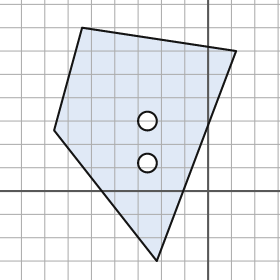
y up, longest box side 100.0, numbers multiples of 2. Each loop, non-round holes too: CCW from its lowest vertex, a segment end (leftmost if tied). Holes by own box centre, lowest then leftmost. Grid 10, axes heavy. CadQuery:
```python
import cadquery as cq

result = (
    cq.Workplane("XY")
    .moveTo(-22.0, -30.0)
    .lineTo(12.0, 60.0)
    .lineTo(-54.0, 70.0)
    .lineTo(-66.0, 26.0)
    .close()
    .moveTo(-26.0, 12.0)
    .circle(4.0)
    .moveTo(-26.0, 30.0)
    .circle(4.0)
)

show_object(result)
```